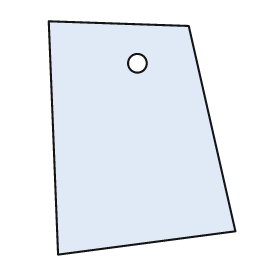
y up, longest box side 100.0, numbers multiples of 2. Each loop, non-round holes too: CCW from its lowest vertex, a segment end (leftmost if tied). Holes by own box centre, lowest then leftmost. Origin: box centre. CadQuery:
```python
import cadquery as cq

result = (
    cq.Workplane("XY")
    .moveTo(-36.0, -50.0)
    .lineTo(40.0, -40.0)
    .lineTo(20.0, 48.0)
    .lineTo(-40.0, 50.0)
    .close()
    .moveTo(-2.0, 32.0)
    .circle(4.0)
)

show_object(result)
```